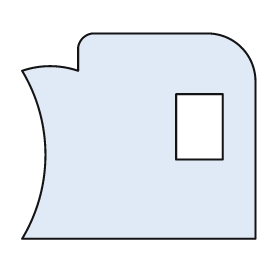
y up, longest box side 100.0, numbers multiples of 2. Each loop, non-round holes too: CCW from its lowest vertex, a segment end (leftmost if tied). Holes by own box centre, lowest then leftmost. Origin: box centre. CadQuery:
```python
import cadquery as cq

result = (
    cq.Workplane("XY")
    .moveTo(-50.0, -44.0)
    .lineTo(50.0, -44.0)
    .lineTo(50.0, 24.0)
    .threePointArc((44.0, 38.0), (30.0, 44.0))
    .lineTo(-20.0, 44.0)
    .threePointArc((-24.0, 42.0), (-26.0, 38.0))
    .lineTo(-26.0, 28.0)
    .threePointArc((-38.0, 30.0), (-50.0, 28.0))
    .threePointArc((-40.0, -8.0), (-50.0, -44.0))
    .close()
    .moveTo(16.0, -10.0)
    .lineTo(36.0, -10.0)
    .lineTo(36.0, 18.0)
    .lineTo(16.0, 18.0)
    .close()
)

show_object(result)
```